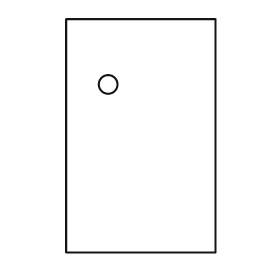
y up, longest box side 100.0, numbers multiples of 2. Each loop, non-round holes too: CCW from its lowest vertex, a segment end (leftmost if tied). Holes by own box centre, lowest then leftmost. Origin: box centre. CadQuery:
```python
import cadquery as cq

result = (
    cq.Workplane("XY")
    .moveTo(-32.0, -50.0)
    .lineTo(32.0, -50.0)
    .lineTo(32.0, 50.0)
    .lineTo(-32.0, 50.0)
    .close()
    .moveTo(-14.0, 22.0)
    .circle(4.0)
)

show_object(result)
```